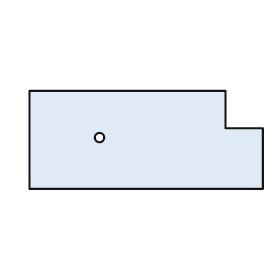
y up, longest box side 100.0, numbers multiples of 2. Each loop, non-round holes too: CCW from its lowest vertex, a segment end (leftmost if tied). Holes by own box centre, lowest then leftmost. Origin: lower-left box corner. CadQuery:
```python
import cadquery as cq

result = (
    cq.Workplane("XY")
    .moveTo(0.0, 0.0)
    .lineTo(100.0, 0.0)
    .lineTo(100.0, 26.0)
    .lineTo(84.0, 26.0)
    .lineTo(84.0, 42.0)
    .lineTo(0.0, 42.0)
    .close()
    .moveTo(30.0, 22.0)
    .circle(2.0)
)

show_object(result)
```